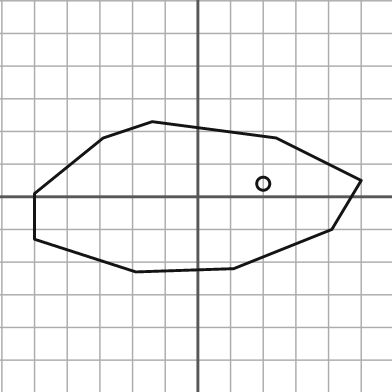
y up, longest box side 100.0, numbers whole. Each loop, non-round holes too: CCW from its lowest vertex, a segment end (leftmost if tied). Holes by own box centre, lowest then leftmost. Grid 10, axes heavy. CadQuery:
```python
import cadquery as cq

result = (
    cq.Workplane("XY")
    .moveTo(-19.0, -23.0)
    .lineTo(11.0, -22.0)
    .lineTo(41.0, -10.0)
    .lineTo(50.0, 5.0)
    .lineTo(24.0, 18.0)
    .lineTo(-14.0, 23.0)
    .lineTo(-29.0, 18.0)
    .lineTo(-50.0, 1.0)
    .lineTo(-50.0, -13.0)
    .close()
    .moveTo(20.0, 4.0)
    .circle(2.0)
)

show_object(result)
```